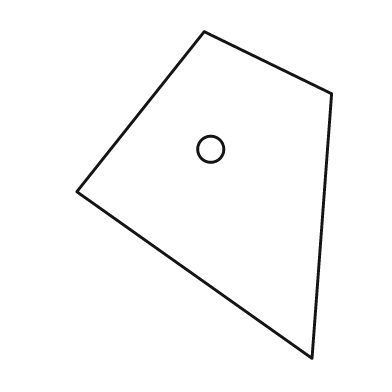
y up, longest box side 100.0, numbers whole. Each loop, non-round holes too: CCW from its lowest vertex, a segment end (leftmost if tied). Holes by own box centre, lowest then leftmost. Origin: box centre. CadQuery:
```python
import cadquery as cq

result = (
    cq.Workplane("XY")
    .moveTo(33.0, -50.0)
    .lineTo(39.0, 31.0)
    .lineTo(0.0, 50.0)
    .lineTo(-39.0, 1.0)
    .close()
    .moveTo(2.0, 14.0)
    .circle(4.0)
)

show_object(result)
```